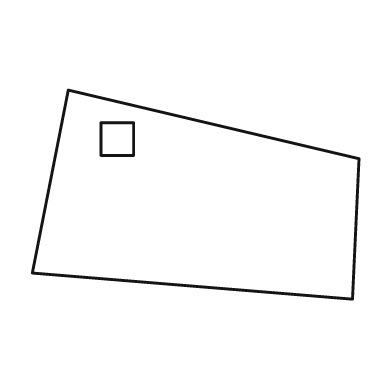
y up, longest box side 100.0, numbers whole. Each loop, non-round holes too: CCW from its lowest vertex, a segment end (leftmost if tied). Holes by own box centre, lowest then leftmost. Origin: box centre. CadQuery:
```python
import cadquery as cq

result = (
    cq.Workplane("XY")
    .moveTo(48.0, -32.0)
    .lineTo(50.0, 11.0)
    .lineTo(-39.0, 32.0)
    .lineTo(-50.0, -24.0)
    .close()
    .moveTo(-29.0, 12.0)
    .lineTo(-19.0, 12.0)
    .lineTo(-19.0, 22.0)
    .lineTo(-29.0, 22.0)
    .close()
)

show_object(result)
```